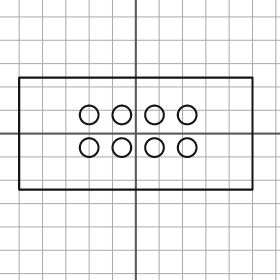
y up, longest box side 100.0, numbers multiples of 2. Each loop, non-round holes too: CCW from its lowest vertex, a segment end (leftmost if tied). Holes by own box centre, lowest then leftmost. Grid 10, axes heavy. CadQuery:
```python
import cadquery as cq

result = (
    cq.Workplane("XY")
    .moveTo(-50.0, -24.0)
    .lineTo(50.0, -24.0)
    .lineTo(50.0, 24.0)
    .lineTo(-50.0, 24.0)
    .close()
    .moveTo(-20.0, -6.0)
    .circle(4.0)
    .moveTo(-6.0, -6.0)
    .circle(4.0)
    .moveTo(8.0, -6.0)
    .circle(4.0)
    .moveTo(22.0, -6.0)
    .circle(4.0)
    .moveTo(-20.0, 8.0)
    .circle(4.0)
    .moveTo(-6.0, 8.0)
    .circle(4.0)
    .moveTo(8.0, 8.0)
    .circle(4.0)
    .moveTo(22.0, 8.0)
    .circle(4.0)
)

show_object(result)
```